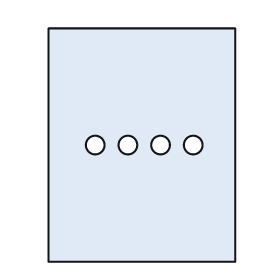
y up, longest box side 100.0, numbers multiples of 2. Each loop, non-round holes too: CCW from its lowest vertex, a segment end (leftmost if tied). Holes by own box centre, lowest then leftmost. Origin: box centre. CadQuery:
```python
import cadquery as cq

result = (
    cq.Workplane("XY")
    .moveTo(-40.0, -50.0)
    .lineTo(40.0, -50.0)
    .lineTo(40.0, 50.0)
    .lineTo(-40.0, 50.0)
    .close()
    .moveTo(-20.0, 0.0)
    .circle(4.0)
    .moveTo(-6.0, 0.0)
    .circle(4.0)
    .moveTo(8.0, 0.0)
    .circle(4.0)
    .moveTo(22.0, 0.0)
    .circle(4.0)
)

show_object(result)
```